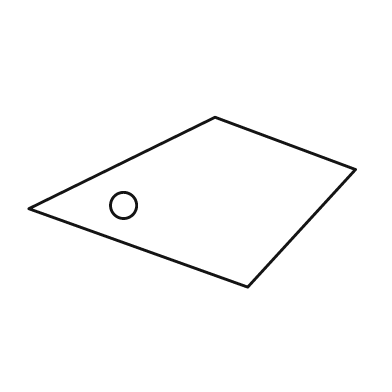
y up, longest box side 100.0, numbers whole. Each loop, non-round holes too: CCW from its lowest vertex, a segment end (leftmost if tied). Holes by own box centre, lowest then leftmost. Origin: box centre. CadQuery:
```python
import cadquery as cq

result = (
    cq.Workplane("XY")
    .moveTo(17.0, -26.0)
    .lineTo(50.0, 10.0)
    .lineTo(7.0, 26.0)
    .lineTo(-50.0, -2.0)
    .close()
    .moveTo(-21.0, -1.0)
    .circle(4.0)
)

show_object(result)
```